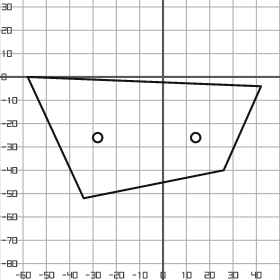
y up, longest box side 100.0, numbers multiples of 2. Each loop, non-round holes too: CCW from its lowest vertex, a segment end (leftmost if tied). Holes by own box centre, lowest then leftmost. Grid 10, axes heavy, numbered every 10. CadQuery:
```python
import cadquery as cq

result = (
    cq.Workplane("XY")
    .moveTo(-34.0, -52.0)
    .lineTo(26.0, -40.0)
    .lineTo(42.0, -4.0)
    .lineTo(-58.0, 0.0)
    .close()
    .moveTo(-28.0, -26.0)
    .circle(2.0)
    .moveTo(14.0, -26.0)
    .circle(2.0)
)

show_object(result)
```